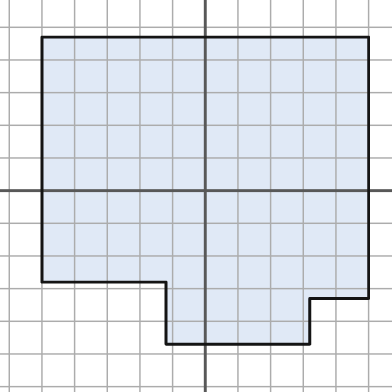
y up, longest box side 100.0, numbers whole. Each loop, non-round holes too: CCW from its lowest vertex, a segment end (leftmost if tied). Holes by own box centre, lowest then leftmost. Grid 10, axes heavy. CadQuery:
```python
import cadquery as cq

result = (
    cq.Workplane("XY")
    .moveTo(-12.0, -47.0)
    .lineTo(32.0, -47.0)
    .lineTo(32.0, -33.0)
    .lineTo(50.0, -33.0)
    .lineTo(50.0, 47.0)
    .lineTo(-50.0, 47.0)
    .lineTo(-50.0, -28.0)
    .lineTo(-12.0, -28.0)
    .close()
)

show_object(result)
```